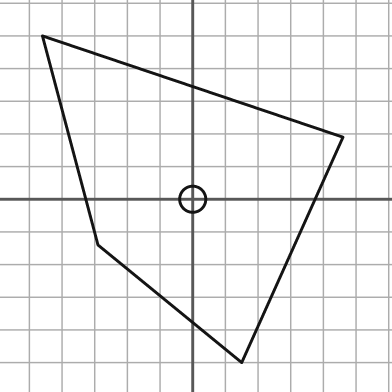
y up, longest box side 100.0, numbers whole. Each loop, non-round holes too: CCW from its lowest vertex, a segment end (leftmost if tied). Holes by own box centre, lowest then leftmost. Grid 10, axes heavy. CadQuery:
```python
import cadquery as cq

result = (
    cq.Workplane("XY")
    .moveTo(15.0, -50.0)
    .lineTo(46.0, 19.0)
    .lineTo(-46.0, 50.0)
    .lineTo(-29.0, -14.0)
    .close()
    .moveTo(0.0, 0.0)
    .circle(4.0)
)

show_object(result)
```